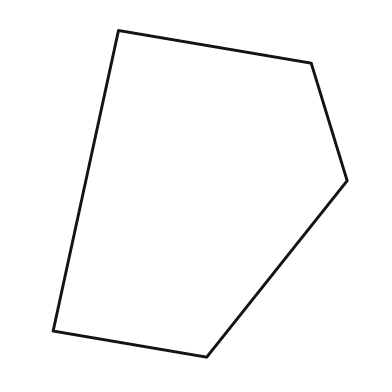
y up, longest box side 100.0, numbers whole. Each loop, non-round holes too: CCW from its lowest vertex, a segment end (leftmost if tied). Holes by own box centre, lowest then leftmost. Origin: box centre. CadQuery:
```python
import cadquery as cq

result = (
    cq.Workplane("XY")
    .moveTo(2.0, -50.0)
    .lineTo(45.0, 4.0)
    .lineTo(34.0, 40.0)
    .lineTo(-25.0, 50.0)
    .lineTo(-45.0, -42.0)
    .close()
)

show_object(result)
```